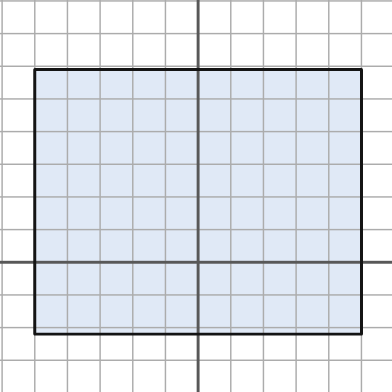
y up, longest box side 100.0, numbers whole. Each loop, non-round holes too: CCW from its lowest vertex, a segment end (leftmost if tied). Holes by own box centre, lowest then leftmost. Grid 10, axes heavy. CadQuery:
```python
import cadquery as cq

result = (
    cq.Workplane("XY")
    .moveTo(-50.0, -22.0)
    .lineTo(50.0, -22.0)
    .lineTo(50.0, 59.0)
    .lineTo(-50.0, 59.0)
    .close()
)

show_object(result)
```